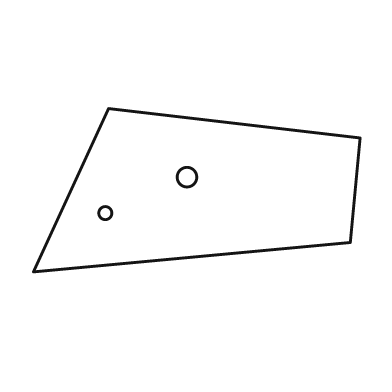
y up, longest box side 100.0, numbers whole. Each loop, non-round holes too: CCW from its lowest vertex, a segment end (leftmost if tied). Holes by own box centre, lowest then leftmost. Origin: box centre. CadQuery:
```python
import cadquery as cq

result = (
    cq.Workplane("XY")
    .moveTo(-50.0, -25.0)
    .lineTo(47.0, -16.0)
    .lineTo(50.0, 16.0)
    .lineTo(-27.0, 25.0)
    .close()
    .moveTo(-28.0, -7.0)
    .circle(2.0)
    .moveTo(-3.0, 4.0)
    .circle(3.0)
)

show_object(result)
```